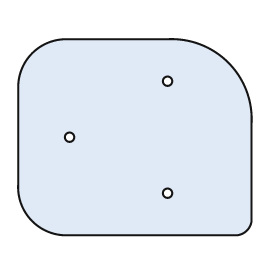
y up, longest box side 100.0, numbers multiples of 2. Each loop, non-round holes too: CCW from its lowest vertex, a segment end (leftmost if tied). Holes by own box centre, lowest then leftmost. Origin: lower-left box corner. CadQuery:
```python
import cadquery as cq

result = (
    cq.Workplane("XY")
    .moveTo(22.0, 0.0)
    .lineTo(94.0, 0.0)
    .threePointArc((98.0, 2.0), (100.0, 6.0))
    .lineTo(100.0, 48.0)
    .threePointArc((90.0, 74.0), (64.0, 84.0))
    .lineTo(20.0, 84.0)
    .threePointArc((6.0, 78.0), (0.0, 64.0))
    .lineTo(0.0, 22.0)
    .threePointArc((6.0, 6.0), (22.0, 0.0))
    .close()
    .moveTo(64.0, 18.0)
    .circle(2.0)
    .moveTo(22.0, 42.0)
    .circle(2.0)
    .moveTo(64.0, 66.0)
    .circle(2.0)
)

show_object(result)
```